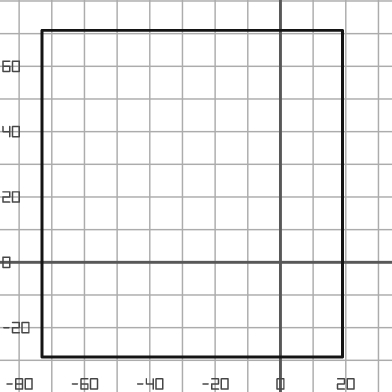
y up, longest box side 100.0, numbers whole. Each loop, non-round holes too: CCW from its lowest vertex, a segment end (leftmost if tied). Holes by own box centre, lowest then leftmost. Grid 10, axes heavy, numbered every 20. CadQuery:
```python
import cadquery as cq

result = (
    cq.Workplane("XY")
    .moveTo(-73.0, -29.0)
    .lineTo(19.0, -29.0)
    .lineTo(19.0, 71.0)
    .lineTo(-73.0, 71.0)
    .close()
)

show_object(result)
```